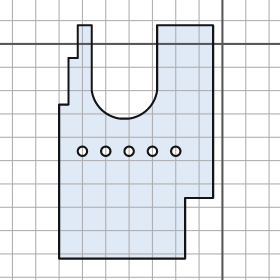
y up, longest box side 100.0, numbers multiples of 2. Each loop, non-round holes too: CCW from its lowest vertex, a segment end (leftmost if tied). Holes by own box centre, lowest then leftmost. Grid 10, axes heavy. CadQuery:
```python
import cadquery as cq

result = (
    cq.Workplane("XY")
    .moveTo(-70.0, -92.0)
    .lineTo(-16.0, -92.0)
    .lineTo(-16.0, -66.0)
    .lineTo(-4.0, -66.0)
    .lineTo(-4.0, 8.0)
    .lineTo(-28.0, 8.0)
    .lineTo(-28.0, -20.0)
    .threePointArc((-32.0, -28.0), (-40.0, -32.0))
    .lineTo(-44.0, -32.0)
    .threePointArc((-52.0, -28.0), (-56.0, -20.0))
    .lineTo(-56.0, 8.0)
    .lineTo(-62.0, 8.0)
    .lineTo(-62.0, -6.0)
    .lineTo(-66.0, -6.0)
    .lineTo(-66.0, -26.0)
    .lineTo(-70.0, -26.0)
    .close()
    .moveTo(-60.0, -46.0)
    .circle(2.0)
    .moveTo(-50.0, -46.0)
    .circle(2.0)
    .moveTo(-40.0, -46.0)
    .circle(2.0)
    .moveTo(-30.0, -46.0)
    .circle(2.0)
    .moveTo(-20.0, -46.0)
    .circle(2.0)
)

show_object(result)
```